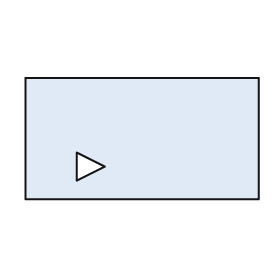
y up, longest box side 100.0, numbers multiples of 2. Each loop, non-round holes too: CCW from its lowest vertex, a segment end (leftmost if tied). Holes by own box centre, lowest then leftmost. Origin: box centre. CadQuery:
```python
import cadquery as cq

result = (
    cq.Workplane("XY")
    .moveTo(-50.0, -26.0)
    .lineTo(50.0, -26.0)
    .lineTo(50.0, 26.0)
    .lineTo(-50.0, 26.0)
    .close()
    .moveTo(-28.0, -18.0)
    .lineTo(-16.0, -12.0)
    .lineTo(-28.0, -6.0)
    .close()
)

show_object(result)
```